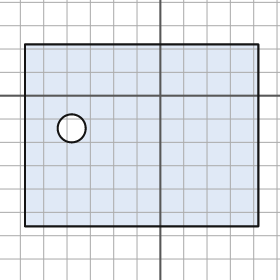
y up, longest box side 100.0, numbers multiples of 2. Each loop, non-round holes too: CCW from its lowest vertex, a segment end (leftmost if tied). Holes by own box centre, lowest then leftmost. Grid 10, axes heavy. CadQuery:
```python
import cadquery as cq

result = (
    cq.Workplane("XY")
    .moveTo(-58.0, -56.0)
    .lineTo(42.0, -56.0)
    .lineTo(42.0, 22.0)
    .lineTo(-58.0, 22.0)
    .close()
    .moveTo(-38.0, -14.0)
    .circle(6.0)
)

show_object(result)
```